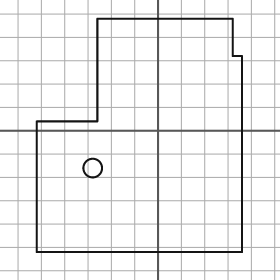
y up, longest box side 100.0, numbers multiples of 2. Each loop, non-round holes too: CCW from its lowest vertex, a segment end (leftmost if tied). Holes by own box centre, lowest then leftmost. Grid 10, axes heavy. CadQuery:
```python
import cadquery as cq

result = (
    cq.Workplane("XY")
    .moveTo(-52.0, -52.0)
    .lineTo(36.0, -52.0)
    .lineTo(36.0, 32.0)
    .lineTo(32.0, 32.0)
    .lineTo(32.0, 48.0)
    .lineTo(-26.0, 48.0)
    .lineTo(-26.0, 4.0)
    .lineTo(-52.0, 4.0)
    .close()
    .moveTo(-28.0, -16.0)
    .circle(4.0)
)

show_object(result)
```